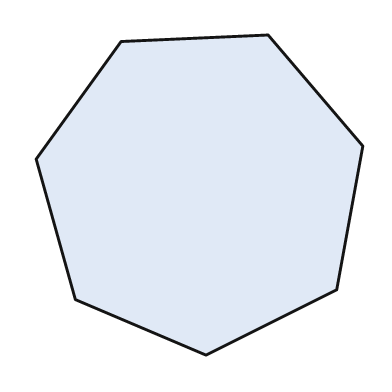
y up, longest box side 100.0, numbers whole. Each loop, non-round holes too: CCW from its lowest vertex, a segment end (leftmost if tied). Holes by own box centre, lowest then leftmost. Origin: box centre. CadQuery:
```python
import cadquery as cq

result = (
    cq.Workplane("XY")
    .moveTo(2.0, -49.0)
    .lineTo(42.0, -29.0)
    .lineTo(50.0, 15.0)
    .lineTo(21.0, 49.0)
    .lineTo(-24.0, 47.0)
    .lineTo(-50.0, 11.0)
    .lineTo(-38.0, -32.0)
    .close()
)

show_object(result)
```